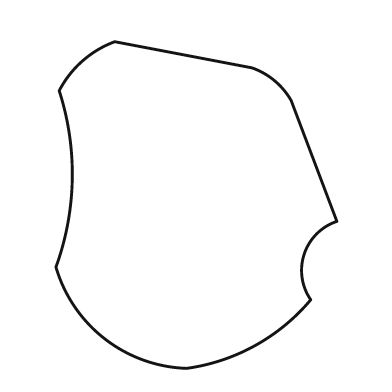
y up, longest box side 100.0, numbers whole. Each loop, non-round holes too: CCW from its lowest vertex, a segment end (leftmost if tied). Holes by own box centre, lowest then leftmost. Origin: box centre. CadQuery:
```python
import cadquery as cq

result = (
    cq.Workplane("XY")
    .moveTo(-3.0, -50.0)
    .threePointArc((18.0, -43.0), (35.0, -29.0))
    .threePointArc((33.0, -15.0), (43.0, -5.0))
    .lineTo(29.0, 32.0)
    .threePointArc((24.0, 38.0), (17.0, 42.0))
    .lineTo(-25.0, 50.0)
    .threePointArc((-35.0, 44.0), (-42.0, 35.0))
    .threePointArc((-38.0, 8.0), (-43.0, -19.0))
    .threePointArc((-28.0, -41.0), (-3.0, -50.0))
    .close()
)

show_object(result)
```